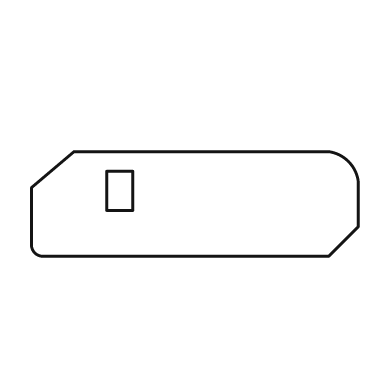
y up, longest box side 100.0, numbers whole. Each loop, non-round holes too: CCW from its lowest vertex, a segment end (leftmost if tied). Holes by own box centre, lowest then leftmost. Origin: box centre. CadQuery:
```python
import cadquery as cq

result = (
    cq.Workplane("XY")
    .moveTo(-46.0, -16.0)
    .lineTo(41.0, -16.0)
    .lineTo(50.0, -7.0)
    .lineTo(50.0, 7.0)
    .threePointArc((47.0, 13.0), (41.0, 16.0))
    .lineTo(-37.0, 16.0)
    .lineTo(-50.0, 5.0)
    .lineTo(-50.0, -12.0)
    .threePointArc((-49.0, -15.0), (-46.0, -16.0))
    .close()
    .moveTo(-27.0, -2.0)
    .lineTo(-19.0, -2.0)
    .lineTo(-19.0, 10.0)
    .lineTo(-27.0, 10.0)
    .close()
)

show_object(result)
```